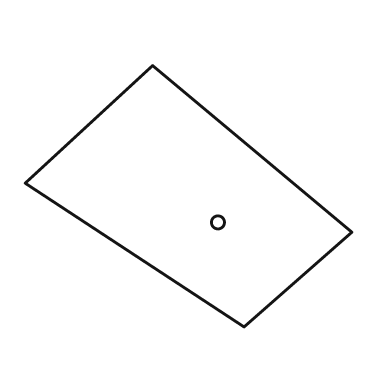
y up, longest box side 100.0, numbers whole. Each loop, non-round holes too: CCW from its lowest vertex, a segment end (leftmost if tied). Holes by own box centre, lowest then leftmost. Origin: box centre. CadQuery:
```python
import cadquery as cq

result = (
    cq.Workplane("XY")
    .moveTo(17.0, -40.0)
    .lineTo(50.0, -11.0)
    .lineTo(-11.0, 40.0)
    .lineTo(-50.0, 4.0)
    .close()
    .moveTo(9.0, -8.0)
    .circle(2.0)
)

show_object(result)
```